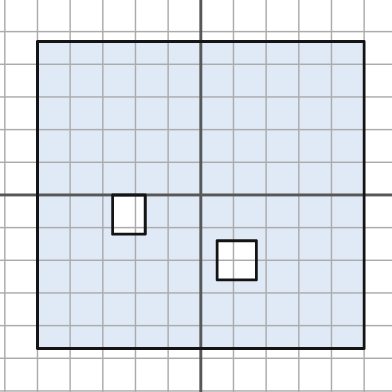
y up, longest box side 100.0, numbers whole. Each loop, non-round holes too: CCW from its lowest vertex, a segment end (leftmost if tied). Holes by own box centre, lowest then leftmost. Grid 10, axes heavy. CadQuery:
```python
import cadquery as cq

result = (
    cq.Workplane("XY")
    .moveTo(-50.0, -47.0)
    .lineTo(50.0, -47.0)
    .lineTo(50.0, 47.0)
    .lineTo(-50.0, 47.0)
    .close()
    .moveTo(5.0, -26.0)
    .lineTo(17.0, -26.0)
    .lineTo(17.0, -14.0)
    .lineTo(5.0, -14.0)
    .close()
    .moveTo(-27.0, -12.0)
    .lineTo(-17.0, -12.0)
    .lineTo(-17.0, 0.0)
    .lineTo(-27.0, 0.0)
    .close()
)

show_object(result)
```